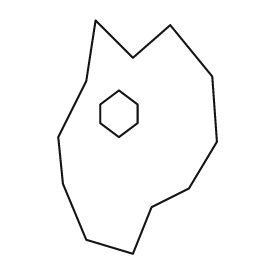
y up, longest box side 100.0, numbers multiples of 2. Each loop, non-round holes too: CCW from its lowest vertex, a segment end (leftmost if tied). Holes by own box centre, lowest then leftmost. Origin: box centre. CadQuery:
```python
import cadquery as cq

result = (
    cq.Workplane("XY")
    .moveTo(-2.0, -50.0)
    .lineTo(6.0, -30.0)
    .lineTo(22.0, -22.0)
    .lineTo(34.0, -2.0)
    .lineTo(32.0, 26.0)
    .lineTo(14.0, 48.0)
    .lineTo(-2.0, 34.0)
    .lineTo(-18.0, 50.0)
    .lineTo(-22.0, 24.0)
    .lineTo(-34.0, 0.0)
    .lineTo(-32.0, -20.0)
    .lineTo(-22.0, -44.0)
    .close()
    .moveTo(-8.0, 0.0)
    .lineTo(0.0, 6.0)
    .lineTo(0.0, 14.0)
    .lineTo(-8.0, 20.0)
    .lineTo(-16.0, 14.0)
    .lineTo(-16.0, 6.0)
    .close()
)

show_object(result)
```